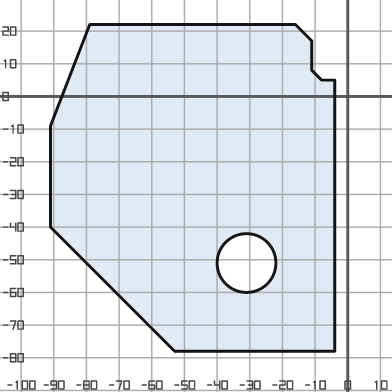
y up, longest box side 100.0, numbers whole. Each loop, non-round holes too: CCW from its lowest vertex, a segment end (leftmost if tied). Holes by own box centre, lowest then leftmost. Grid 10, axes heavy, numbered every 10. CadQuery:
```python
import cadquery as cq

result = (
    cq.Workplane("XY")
    .moveTo(-53.0, -78.0)
    .lineTo(-4.0, -78.0)
    .lineTo(-4.0, 5.0)
    .lineTo(-8.0, 5.0)
    .lineTo(-11.0, 8.0)
    .lineTo(-11.0, 17.0)
    .lineTo(-16.0, 22.0)
    .lineTo(-79.0, 22.0)
    .lineTo(-91.0, -9.0)
    .lineTo(-91.0, -40.0)
    .close()
    .moveTo(-31.0, -51.0)
    .circle(9.0)
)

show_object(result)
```